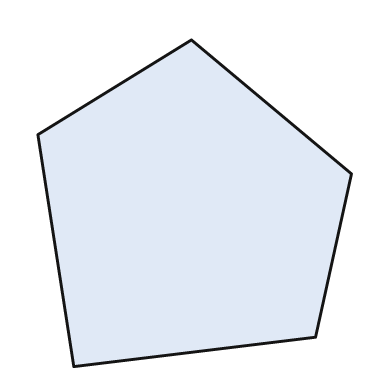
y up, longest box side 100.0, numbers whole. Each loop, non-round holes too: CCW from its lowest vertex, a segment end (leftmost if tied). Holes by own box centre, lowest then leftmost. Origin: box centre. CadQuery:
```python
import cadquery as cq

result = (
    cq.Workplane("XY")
    .moveTo(-37.0, -50.0)
    .lineTo(37.0, -41.0)
    .lineTo(48.0, 9.0)
    .lineTo(-1.0, 50.0)
    .lineTo(-48.0, 21.0)
    .close()
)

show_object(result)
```